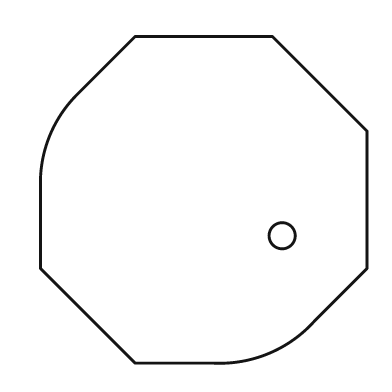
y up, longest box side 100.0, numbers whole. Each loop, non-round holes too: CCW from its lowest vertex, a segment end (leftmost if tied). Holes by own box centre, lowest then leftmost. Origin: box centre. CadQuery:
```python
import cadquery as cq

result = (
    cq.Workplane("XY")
    .moveTo(-21.0, -50.0)
    .lineTo(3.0, -50.0)
    .threePointArc((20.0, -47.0), (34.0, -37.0))
    .lineTo(50.0, -21.0)
    .lineTo(50.0, 21.0)
    .lineTo(21.0, 50.0)
    .lineTo(-21.0, 50.0)
    .lineTo(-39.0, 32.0)
    .threePointArc((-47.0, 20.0), (-50.0, 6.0))
    .lineTo(-50.0, -21.0)
    .close()
    .moveTo(24.0, -11.0)
    .circle(4.0)
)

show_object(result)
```